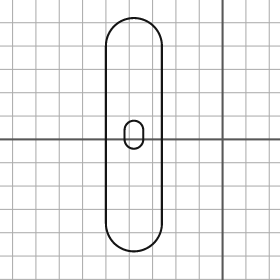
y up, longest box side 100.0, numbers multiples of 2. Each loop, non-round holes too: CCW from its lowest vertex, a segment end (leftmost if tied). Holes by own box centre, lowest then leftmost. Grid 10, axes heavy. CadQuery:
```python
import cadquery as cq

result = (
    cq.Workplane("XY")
    .moveTo(-50.0, -36.0)
    .threePointArc((-38.0, -48.0), (-26.0, -36.0))
    .lineTo(-26.0, 40.0)
    .threePointArc((-38.0, 52.0), (-50.0, 40.0))
    .close()
    .moveTo(-42.0, 0.0)
    .threePointArc((-38.0, -4.0), (-34.0, 0.0))
    .lineTo(-34.0, 4.0)
    .threePointArc((-38.0, 8.0), (-42.0, 4.0))
    .close()
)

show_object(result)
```